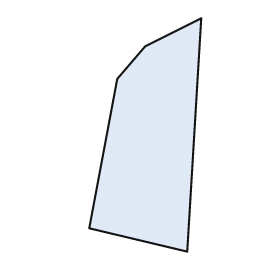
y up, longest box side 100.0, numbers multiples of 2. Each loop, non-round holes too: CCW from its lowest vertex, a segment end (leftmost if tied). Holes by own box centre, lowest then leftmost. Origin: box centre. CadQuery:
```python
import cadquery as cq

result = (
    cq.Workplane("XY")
    .moveTo(18.0, -50.0)
    .lineTo(24.0, 50.0)
    .lineTo(0.0, 38.0)
    .lineTo(-12.0, 24.0)
    .lineTo(-24.0, -40.0)
    .close()
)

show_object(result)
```